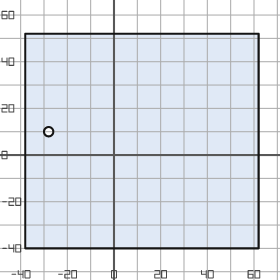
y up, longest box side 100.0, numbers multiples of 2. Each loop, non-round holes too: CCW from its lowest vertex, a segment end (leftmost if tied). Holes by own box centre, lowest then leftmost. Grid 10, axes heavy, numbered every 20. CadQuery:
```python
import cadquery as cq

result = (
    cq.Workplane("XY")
    .moveTo(-38.0, -40.0)
    .lineTo(62.0, -40.0)
    .lineTo(62.0, 52.0)
    .lineTo(-38.0, 52.0)
    .close()
    .moveTo(-28.0, 10.0)
    .circle(2.0)
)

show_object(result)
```